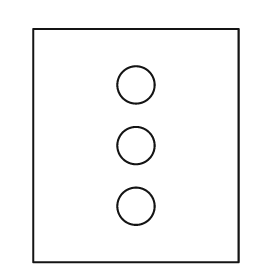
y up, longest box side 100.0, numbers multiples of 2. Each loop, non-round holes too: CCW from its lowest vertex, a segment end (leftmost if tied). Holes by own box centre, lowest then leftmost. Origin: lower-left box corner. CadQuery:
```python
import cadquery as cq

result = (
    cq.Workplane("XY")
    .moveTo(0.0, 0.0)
    .lineTo(88.0, 0.0)
    .lineTo(88.0, 100.0)
    .lineTo(0.0, 100.0)
    .close()
    .moveTo(44.0, 24.0)
    .circle(8.0)
    .moveTo(44.0, 50.0)
    .circle(8.0)
    .moveTo(44.0, 76.0)
    .circle(8.0)
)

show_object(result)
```